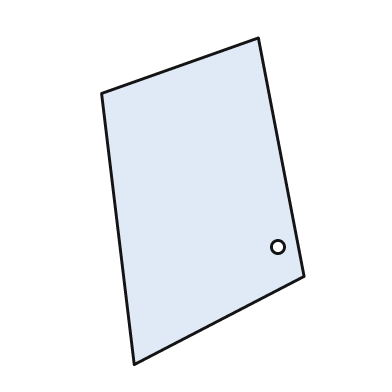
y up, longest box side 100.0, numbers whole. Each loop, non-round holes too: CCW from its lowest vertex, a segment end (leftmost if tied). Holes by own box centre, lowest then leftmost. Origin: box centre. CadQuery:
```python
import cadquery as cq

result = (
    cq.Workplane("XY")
    .moveTo(-21.0, -50.0)
    .lineTo(31.0, -23.0)
    .lineTo(17.0, 50.0)
    .lineTo(-31.0, 33.0)
    .close()
    .moveTo(23.0, -14.0)
    .circle(2.0)
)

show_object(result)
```